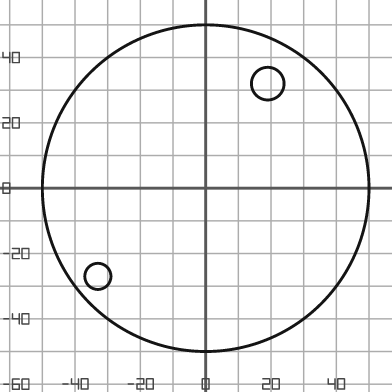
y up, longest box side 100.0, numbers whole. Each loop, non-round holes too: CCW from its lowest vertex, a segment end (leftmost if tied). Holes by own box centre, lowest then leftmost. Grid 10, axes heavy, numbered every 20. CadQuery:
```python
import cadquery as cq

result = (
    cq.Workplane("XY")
    .moveTo(0.0, 0.0)
    .circle(50.0)
    .moveTo(-33.0, -27.0)
    .circle(4.0)
    .moveTo(19.0, 32.0)
    .circle(5.0)
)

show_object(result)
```